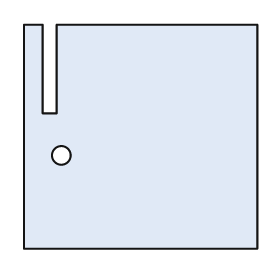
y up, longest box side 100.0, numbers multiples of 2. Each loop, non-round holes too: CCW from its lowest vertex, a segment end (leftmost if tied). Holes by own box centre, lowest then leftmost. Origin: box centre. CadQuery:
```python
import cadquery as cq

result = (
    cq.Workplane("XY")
    .moveTo(-50.0, -48.0)
    .lineTo(50.0, -48.0)
    .lineTo(50.0, 48.0)
    .lineTo(-36.0, 48.0)
    .lineTo(-36.0, 10.0)
    .lineTo(-42.0, 10.0)
    .lineTo(-42.0, 48.0)
    .lineTo(-50.0, 48.0)
    .close()
    .moveTo(-34.0, -8.0)
    .circle(4.0)
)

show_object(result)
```